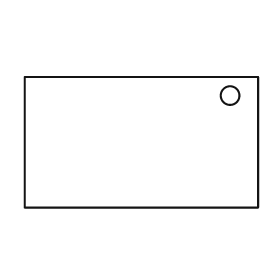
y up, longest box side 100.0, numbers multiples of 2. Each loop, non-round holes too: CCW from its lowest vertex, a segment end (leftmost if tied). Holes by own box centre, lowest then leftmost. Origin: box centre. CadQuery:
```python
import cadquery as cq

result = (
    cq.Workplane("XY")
    .moveTo(-50.0, -28.0)
    .lineTo(50.0, -28.0)
    .lineTo(50.0, 28.0)
    .lineTo(-50.0, 28.0)
    .close()
    .moveTo(38.0, 20.0)
    .circle(4.0)
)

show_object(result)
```